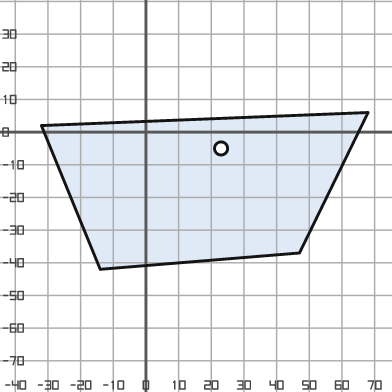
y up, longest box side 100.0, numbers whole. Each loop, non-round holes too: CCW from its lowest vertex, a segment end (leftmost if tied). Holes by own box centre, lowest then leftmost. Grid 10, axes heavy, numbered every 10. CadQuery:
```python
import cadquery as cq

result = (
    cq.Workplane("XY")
    .moveTo(-14.0, -42.0)
    .lineTo(47.0, -37.0)
    .lineTo(68.0, 6.0)
    .lineTo(-32.0, 2.0)
    .close()
    .moveTo(23.0, -5.0)
    .circle(2.0)
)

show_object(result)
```